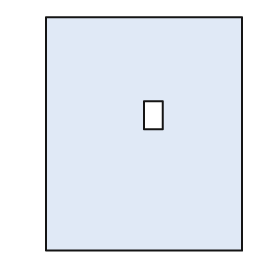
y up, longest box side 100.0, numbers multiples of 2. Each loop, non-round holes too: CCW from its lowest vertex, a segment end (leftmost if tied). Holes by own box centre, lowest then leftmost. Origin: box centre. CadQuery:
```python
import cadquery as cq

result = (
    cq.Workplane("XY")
    .moveTo(-42.0, -50.0)
    .lineTo(42.0, -50.0)
    .lineTo(42.0, 50.0)
    .lineTo(-42.0, 50.0)
    .close()
    .moveTo(0.0, 2.0)
    .lineTo(8.0, 2.0)
    .lineTo(8.0, 14.0)
    .lineTo(0.0, 14.0)
    .close()
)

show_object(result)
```